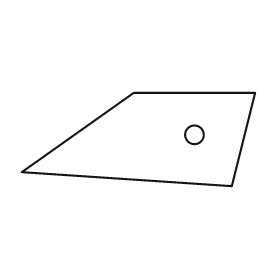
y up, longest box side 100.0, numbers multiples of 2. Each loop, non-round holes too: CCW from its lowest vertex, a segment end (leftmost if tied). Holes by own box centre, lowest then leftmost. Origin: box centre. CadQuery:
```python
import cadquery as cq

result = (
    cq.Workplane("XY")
    .moveTo(40.0, -20.0)
    .lineTo(50.0, 20.0)
    .lineTo(-2.0, 20.0)
    .lineTo(-50.0, -14.0)
    .close()
    .moveTo(24.0, 2.0)
    .circle(4.0)
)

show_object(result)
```